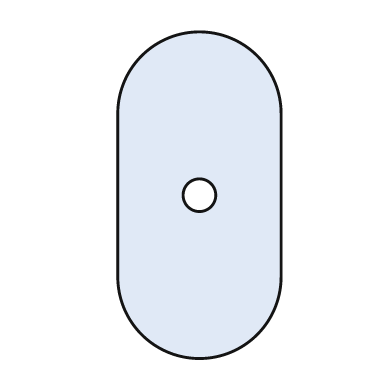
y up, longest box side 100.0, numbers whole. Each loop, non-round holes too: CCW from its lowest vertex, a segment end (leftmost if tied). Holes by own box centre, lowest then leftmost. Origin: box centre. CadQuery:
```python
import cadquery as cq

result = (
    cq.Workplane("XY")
    .moveTo(-25.0, -25.0)
    .threePointArc((0.0, -50.0), (25.0, -25.0))
    .lineTo(25.0, 25.0)
    .threePointArc((0.0, 50.0), (-25.0, 25.0))
    .close()
    .moveTo(0.0, 0.0)
    .circle(5.0)
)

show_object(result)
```